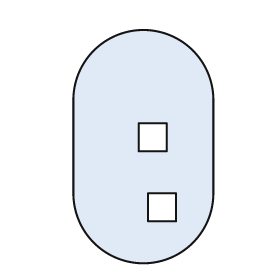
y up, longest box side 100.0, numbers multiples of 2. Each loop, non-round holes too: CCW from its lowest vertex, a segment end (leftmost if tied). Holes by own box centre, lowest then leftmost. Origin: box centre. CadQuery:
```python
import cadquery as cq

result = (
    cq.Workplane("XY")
    .moveTo(-30.0, -20.0)
    .threePointArc((0.0, -50.0), (30.0, -20.0))
    .lineTo(30.0, 20.0)
    .threePointArc((0.0, 50.0), (-30.0, 20.0))
    .close()
    .moveTo(2.0, -32.0)
    .lineTo(14.0, -32.0)
    .lineTo(14.0, -20.0)
    .lineTo(2.0, -20.0)
    .close()
    .moveTo(-2.0, -2.0)
    .lineTo(10.0, -2.0)
    .lineTo(10.0, 10.0)
    .lineTo(-2.0, 10.0)
    .close()
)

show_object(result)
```